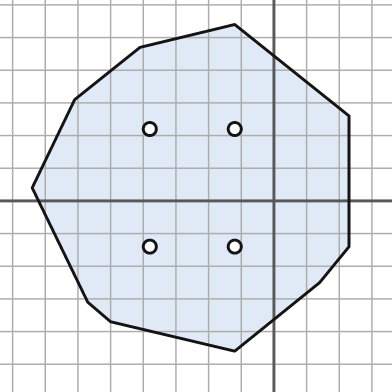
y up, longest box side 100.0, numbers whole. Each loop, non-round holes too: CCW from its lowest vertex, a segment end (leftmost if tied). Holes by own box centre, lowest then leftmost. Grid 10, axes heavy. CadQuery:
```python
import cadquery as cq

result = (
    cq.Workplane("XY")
    .moveTo(-12.0, -46.0)
    .lineTo(14.0, -25.0)
    .lineTo(23.0, -14.0)
    .lineTo(23.0, 26.0)
    .lineTo(-12.0, 54.0)
    .lineTo(-41.0, 47.0)
    .lineTo(-61.0, 31.0)
    .lineTo(-74.0, 4.0)
    .lineTo(-57.0, -31.0)
    .lineTo(-50.0, -37.0)
    .close()
    .moveTo(-38.0, -14.0)
    .circle(2.0)
    .moveTo(-12.0, -14.0)
    .circle(2.0)
    .moveTo(-38.0, 22.0)
    .circle(2.0)
    .moveTo(-12.0, 22.0)
    .circle(2.0)
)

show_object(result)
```